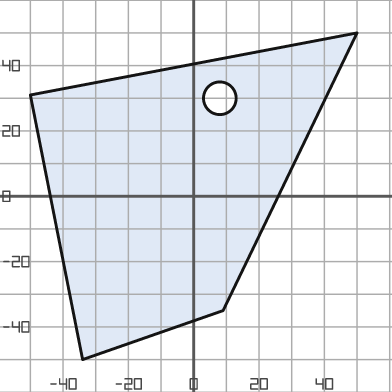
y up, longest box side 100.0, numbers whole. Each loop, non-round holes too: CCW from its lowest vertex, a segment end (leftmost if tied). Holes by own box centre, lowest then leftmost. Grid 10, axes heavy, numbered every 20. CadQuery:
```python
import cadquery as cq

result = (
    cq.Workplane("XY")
    .moveTo(-34.0, -50.0)
    .lineTo(9.0, -35.0)
    .lineTo(50.0, 50.0)
    .lineTo(-50.0, 31.0)
    .close()
    .moveTo(8.0, 30.0)
    .circle(5.0)
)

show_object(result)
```